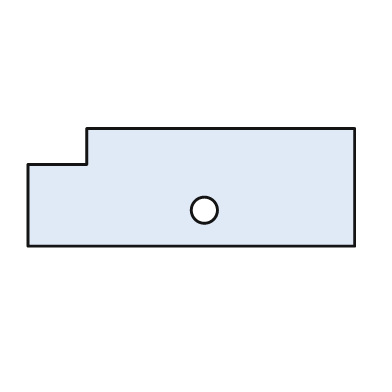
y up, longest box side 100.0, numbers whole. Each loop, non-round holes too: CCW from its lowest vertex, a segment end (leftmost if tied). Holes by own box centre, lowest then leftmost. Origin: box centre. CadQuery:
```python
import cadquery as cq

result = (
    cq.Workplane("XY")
    .moveTo(-50.0, -18.0)
    .lineTo(50.0, -18.0)
    .lineTo(50.0, 18.0)
    .lineTo(-32.0, 18.0)
    .lineTo(-32.0, 7.0)
    .lineTo(-50.0, 7.0)
    .close()
    .moveTo(4.0, -7.0)
    .circle(4.0)
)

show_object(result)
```